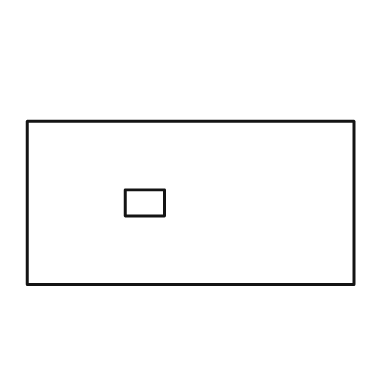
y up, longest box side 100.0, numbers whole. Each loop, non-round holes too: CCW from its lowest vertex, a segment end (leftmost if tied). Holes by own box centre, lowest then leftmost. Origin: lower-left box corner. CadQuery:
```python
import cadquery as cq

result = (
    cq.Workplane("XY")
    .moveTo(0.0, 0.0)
    .lineTo(100.0, 0.0)
    .lineTo(100.0, 50.0)
    .lineTo(0.0, 50.0)
    .close()
    .moveTo(30.0, 21.0)
    .lineTo(42.0, 21.0)
    .lineTo(42.0, 29.0)
    .lineTo(30.0, 29.0)
    .close()
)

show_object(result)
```